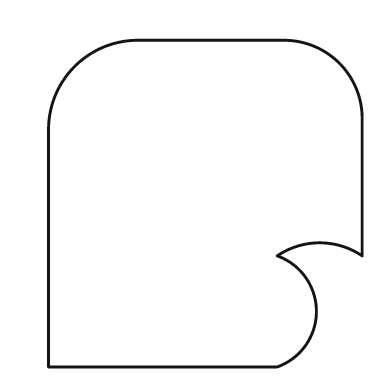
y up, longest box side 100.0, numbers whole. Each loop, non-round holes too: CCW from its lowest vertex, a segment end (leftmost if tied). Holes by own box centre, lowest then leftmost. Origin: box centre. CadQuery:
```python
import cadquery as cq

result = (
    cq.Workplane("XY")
    .moveTo(-48.0, -50.0)
    .lineTo(22.0, -50.0)
    .threePointArc((34.0, -33.0), (22.0, -16.0))
    .threePointArc((35.0, -12.0), (48.0, -16.0))
    .lineTo(48.0, 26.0)
    .threePointArc((41.0, 43.0), (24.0, 50.0))
    .lineTo(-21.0, 50.0)
    .threePointArc((-40.0, 42.0), (-48.0, 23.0))
    .close()
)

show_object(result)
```